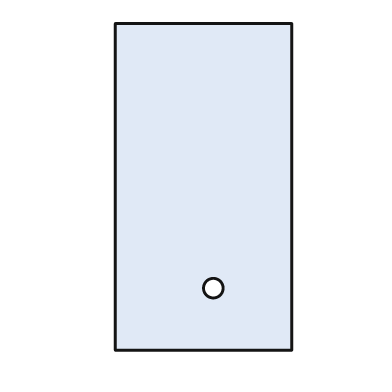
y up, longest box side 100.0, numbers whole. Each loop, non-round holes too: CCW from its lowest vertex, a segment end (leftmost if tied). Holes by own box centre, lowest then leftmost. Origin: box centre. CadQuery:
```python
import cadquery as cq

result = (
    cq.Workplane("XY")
    .moveTo(-27.0, -50.0)
    .lineTo(27.0, -50.0)
    .lineTo(27.0, 50.0)
    .lineTo(-27.0, 50.0)
    .close()
    .moveTo(3.0, -31.0)
    .circle(3.0)
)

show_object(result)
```